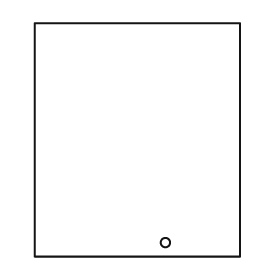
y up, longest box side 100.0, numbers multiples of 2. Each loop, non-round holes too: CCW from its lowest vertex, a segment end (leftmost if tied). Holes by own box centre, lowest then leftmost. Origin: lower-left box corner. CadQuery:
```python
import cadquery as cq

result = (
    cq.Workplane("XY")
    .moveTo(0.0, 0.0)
    .lineTo(88.0, 0.0)
    .lineTo(88.0, 100.0)
    .lineTo(0.0, 100.0)
    .close()
    .moveTo(56.0, 6.0)
    .circle(2.0)
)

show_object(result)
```